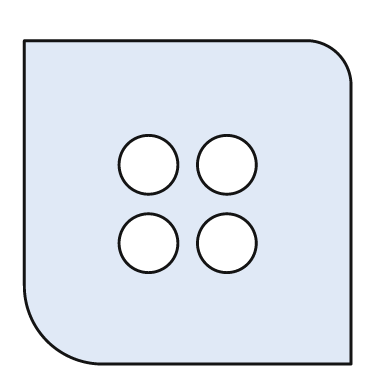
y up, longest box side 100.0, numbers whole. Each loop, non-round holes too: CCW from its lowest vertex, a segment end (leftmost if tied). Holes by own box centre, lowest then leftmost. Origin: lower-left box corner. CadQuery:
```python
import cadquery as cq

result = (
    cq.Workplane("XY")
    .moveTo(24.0, 0.0)
    .lineTo(100.0, 0.0)
    .lineTo(100.0, 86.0)
    .threePointArc((96.0, 95.0), (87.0, 99.0))
    .lineTo(0.0, 99.0)
    .lineTo(0.0, 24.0)
    .threePointArc((7.0, 7.0), (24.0, 0.0))
    .close()
    .moveTo(38.0, 37.0)
    .circle(9.0)
    .moveTo(62.0, 37.0)
    .circle(9.0)
    .moveTo(38.0, 61.0)
    .circle(9.0)
    .moveTo(62.0, 61.0)
    .circle(9.0)
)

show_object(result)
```